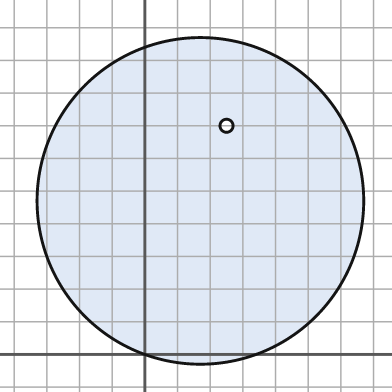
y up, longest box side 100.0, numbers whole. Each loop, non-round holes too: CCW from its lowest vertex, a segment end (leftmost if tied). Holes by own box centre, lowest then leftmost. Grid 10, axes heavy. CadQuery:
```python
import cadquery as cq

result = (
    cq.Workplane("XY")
    .moveTo(17.0, 47.0)
    .circle(50.0)
    .moveTo(25.0, 70.0)
    .circle(2.0)
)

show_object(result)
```